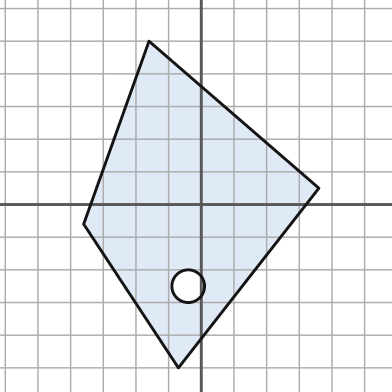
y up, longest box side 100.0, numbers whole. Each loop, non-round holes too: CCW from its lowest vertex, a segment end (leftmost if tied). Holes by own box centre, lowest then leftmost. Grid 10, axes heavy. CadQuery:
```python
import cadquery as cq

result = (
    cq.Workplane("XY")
    .moveTo(-7.0, -50.0)
    .lineTo(36.0, 5.0)
    .lineTo(-16.0, 50.0)
    .lineTo(-36.0, -6.0)
    .close()
    .moveTo(-4.0, -25.0)
    .circle(5.0)
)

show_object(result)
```